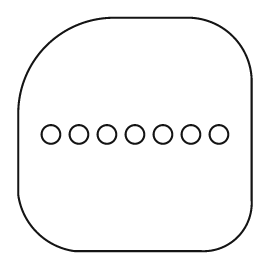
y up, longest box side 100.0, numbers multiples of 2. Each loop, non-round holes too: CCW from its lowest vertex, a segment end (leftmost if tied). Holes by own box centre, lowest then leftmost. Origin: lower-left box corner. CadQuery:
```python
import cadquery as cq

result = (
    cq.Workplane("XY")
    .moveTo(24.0, 0.0)
    .lineTo(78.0, 0.0)
    .threePointArc((94.0, 6.0), (100.0, 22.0))
    .lineTo(100.0, 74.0)
    .threePointArc((92.0, 92.0), (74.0, 100.0))
    .lineTo(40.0, 100.0)
    .threePointArc((12.0, 88.0), (0.0, 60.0))
    .lineTo(0.0, 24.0)
    .threePointArc((8.0, 8.0), (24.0, 0.0))
    .close()
    .moveTo(14.0, 50.0)
    .circle(4.0)
    .moveTo(26.0, 50.0)
    .circle(4.0)
    .moveTo(38.0, 50.0)
    .circle(4.0)
    .moveTo(50.0, 50.0)
    .circle(4.0)
    .moveTo(62.0, 50.0)
    .circle(4.0)
    .moveTo(74.0, 50.0)
    .circle(4.0)
    .moveTo(86.0, 50.0)
    .circle(4.0)
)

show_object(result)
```